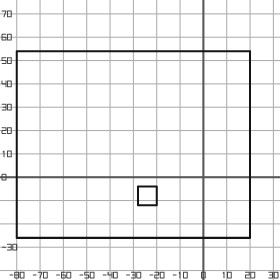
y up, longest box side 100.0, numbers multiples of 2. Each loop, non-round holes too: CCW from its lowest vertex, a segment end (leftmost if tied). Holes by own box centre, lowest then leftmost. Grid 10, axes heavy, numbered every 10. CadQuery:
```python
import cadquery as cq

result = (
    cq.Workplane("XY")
    .moveTo(-80.0, -26.0)
    .lineTo(20.0, -26.0)
    .lineTo(20.0, 54.0)
    .lineTo(-80.0, 54.0)
    .close()
    .moveTo(-28.0, -12.0)
    .lineTo(-20.0, -12.0)
    .lineTo(-20.0, -4.0)
    .lineTo(-28.0, -4.0)
    .close()
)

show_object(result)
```